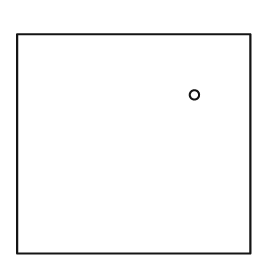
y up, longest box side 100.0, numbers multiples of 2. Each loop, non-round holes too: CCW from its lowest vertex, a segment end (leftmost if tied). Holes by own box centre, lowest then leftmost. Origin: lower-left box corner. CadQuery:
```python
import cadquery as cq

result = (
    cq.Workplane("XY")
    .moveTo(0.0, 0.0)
    .lineTo(100.0, 0.0)
    .lineTo(100.0, 94.0)
    .lineTo(0.0, 94.0)
    .close()
    .moveTo(76.0, 68.0)
    .circle(2.0)
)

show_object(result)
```